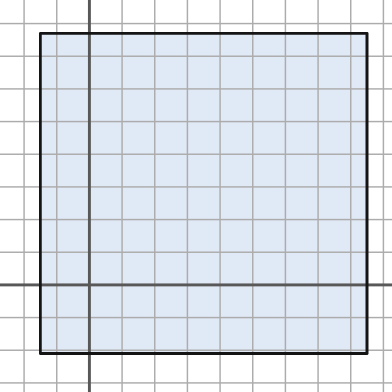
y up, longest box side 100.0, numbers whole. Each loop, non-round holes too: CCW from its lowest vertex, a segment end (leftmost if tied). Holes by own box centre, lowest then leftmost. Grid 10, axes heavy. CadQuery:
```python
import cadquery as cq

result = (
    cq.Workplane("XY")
    .moveTo(-15.0, -21.0)
    .lineTo(85.0, -21.0)
    .lineTo(85.0, 77.0)
    .lineTo(-15.0, 77.0)
    .close()
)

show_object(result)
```